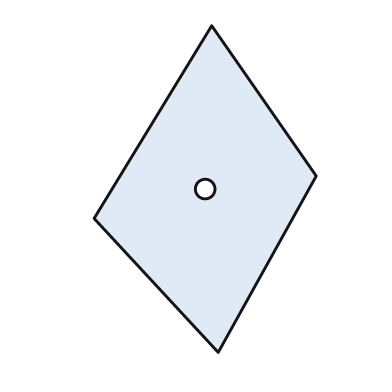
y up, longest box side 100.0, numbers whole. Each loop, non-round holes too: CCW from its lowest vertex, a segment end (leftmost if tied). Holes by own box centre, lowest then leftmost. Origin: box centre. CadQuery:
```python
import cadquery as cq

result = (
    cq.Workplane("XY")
    .moveTo(4.0, -50.0)
    .lineTo(34.0, 4.0)
    .lineTo(2.0, 50.0)
    .lineTo(-34.0, -9.0)
    .close()
    .moveTo(0.0, 0.0)
    .circle(3.0)
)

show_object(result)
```